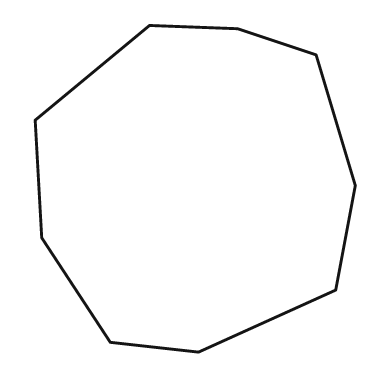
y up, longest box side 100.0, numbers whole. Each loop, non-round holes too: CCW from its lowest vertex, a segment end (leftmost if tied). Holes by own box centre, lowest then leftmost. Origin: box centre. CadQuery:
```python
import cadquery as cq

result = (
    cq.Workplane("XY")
    .moveTo(1.0, -50.0)
    .lineTo(43.0, -31.0)
    .lineTo(49.0, 1.0)
    .lineTo(37.0, 41.0)
    .lineTo(13.0, 49.0)
    .lineTo(-14.0, 50.0)
    .lineTo(-49.0, 21.0)
    .lineTo(-47.0, -15.0)
    .lineTo(-26.0, -47.0)
    .close()
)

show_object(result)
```